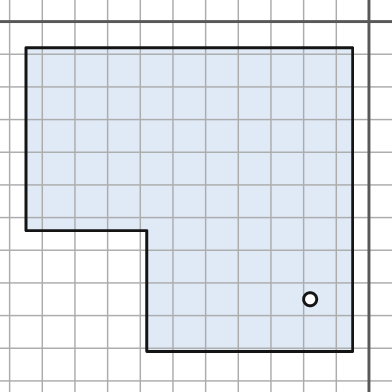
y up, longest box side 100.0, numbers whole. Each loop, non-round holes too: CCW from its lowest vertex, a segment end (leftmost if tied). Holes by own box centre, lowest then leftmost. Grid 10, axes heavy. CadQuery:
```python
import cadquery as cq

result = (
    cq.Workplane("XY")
    .moveTo(-68.0, -101.0)
    .lineTo(-5.0, -101.0)
    .lineTo(-5.0, -8.0)
    .lineTo(-105.0, -8.0)
    .lineTo(-105.0, -64.0)
    .lineTo(-68.0, -64.0)
    .close()
    .moveTo(-18.0, -85.0)
    .circle(2.0)
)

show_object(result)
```